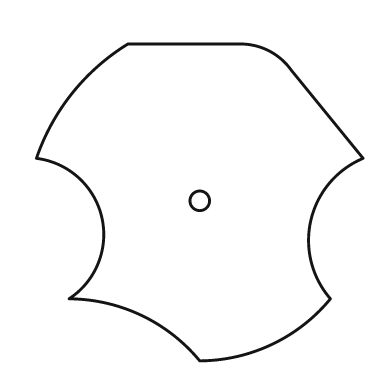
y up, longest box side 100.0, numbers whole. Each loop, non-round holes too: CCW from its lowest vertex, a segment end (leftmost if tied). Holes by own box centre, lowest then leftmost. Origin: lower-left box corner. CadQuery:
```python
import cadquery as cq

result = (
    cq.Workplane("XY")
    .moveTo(50.0, 0.0)
    .threePointArc((72.0, 5.0), (90.0, 19.0))
    .threePointArc((84.0, 43.0), (100.0, 62.0))
    .lineTo(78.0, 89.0)
    .threePointArc((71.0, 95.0), (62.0, 97.0))
    .lineTo(28.0, 97.0)
    .threePointArc((11.0, 82.0), (0.0, 62.0))
    .threePointArc((20.0, 44.0), (10.0, 19.0))
    .threePointArc((32.0, 14.0), (50.0, 0.0))
    .close()
    .moveTo(50.0, 49.0)
    .circle(3.0)
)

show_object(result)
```